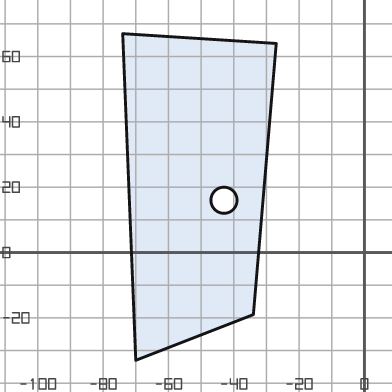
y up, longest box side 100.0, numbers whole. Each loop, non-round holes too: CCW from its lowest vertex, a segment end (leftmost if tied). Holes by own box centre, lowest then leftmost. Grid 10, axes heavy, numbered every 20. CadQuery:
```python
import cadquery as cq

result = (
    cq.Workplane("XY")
    .moveTo(-70.0, -33.0)
    .lineTo(-34.0, -19.0)
    .lineTo(-27.0, 64.0)
    .lineTo(-74.0, 67.0)
    .close()
    .moveTo(-43.0, 16.0)
    .circle(4.0)
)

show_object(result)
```